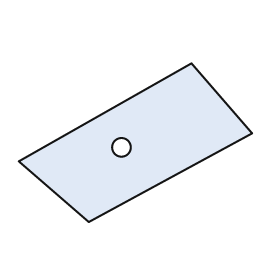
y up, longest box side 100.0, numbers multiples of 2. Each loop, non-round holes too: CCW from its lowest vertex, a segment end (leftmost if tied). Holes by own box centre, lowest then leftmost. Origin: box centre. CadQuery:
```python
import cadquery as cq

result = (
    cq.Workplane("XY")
    .moveTo(-20.0, -34.0)
    .lineTo(50.0, 4.0)
    .lineTo(24.0, 34.0)
    .lineTo(-50.0, -8.0)
    .close()
    .moveTo(-6.0, -2.0)
    .circle(4.0)
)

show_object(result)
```